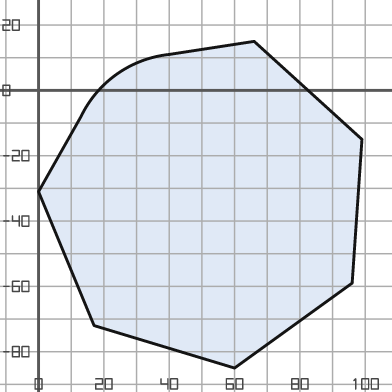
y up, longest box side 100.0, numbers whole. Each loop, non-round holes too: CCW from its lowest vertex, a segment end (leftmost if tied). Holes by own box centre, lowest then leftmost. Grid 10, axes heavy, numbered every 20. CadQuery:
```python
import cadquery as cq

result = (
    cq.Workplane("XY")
    .moveTo(60.0, -85.0)
    .lineTo(96.0, -59.0)
    .lineTo(99.0, -15.0)
    .lineTo(66.0, 15.0)
    .lineTo(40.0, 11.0)
    .threePointArc((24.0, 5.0), (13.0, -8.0))
    .lineTo(0.0, -31.0)
    .lineTo(17.0, -72.0)
    .close()
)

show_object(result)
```